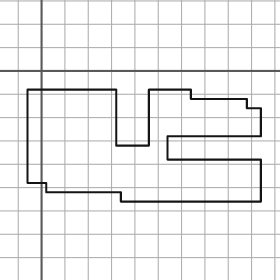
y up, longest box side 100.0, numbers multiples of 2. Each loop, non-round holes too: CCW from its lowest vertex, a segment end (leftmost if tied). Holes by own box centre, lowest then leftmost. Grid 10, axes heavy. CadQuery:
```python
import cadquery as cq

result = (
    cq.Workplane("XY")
    .moveTo(34.0, -56.0)
    .lineTo(94.0, -56.0)
    .lineTo(94.0, -38.0)
    .lineTo(54.0, -38.0)
    .lineTo(54.0, -28.0)
    .lineTo(94.0, -28.0)
    .lineTo(94.0, -16.0)
    .lineTo(88.0, -16.0)
    .lineTo(88.0, -12.0)
    .lineTo(64.0, -12.0)
    .lineTo(64.0, -8.0)
    .lineTo(46.0, -8.0)
    .lineTo(46.0, -32.0)
    .lineTo(32.0, -32.0)
    .lineTo(32.0, -8.0)
    .lineTo(-6.0, -8.0)
    .lineTo(-6.0, -48.0)
    .lineTo(2.0, -48.0)
    .lineTo(2.0, -52.0)
    .lineTo(34.0, -52.0)
    .close()
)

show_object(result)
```